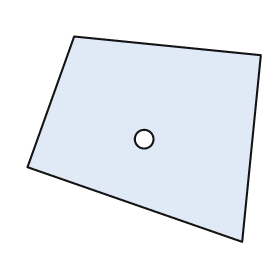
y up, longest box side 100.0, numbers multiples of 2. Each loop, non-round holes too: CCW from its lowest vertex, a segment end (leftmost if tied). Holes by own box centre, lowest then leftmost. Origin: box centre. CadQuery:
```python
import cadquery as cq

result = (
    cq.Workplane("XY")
    .moveTo(42.0, -44.0)
    .lineTo(50.0, 36.0)
    .lineTo(-30.0, 44.0)
    .lineTo(-50.0, -12.0)
    .close()
    .moveTo(0.0, 0.0)
    .circle(4.0)
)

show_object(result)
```